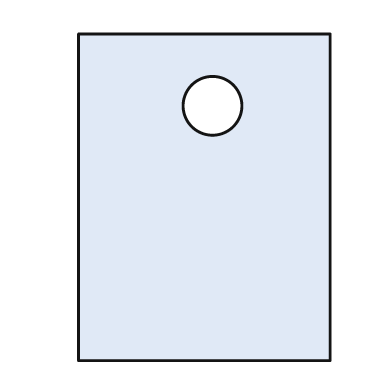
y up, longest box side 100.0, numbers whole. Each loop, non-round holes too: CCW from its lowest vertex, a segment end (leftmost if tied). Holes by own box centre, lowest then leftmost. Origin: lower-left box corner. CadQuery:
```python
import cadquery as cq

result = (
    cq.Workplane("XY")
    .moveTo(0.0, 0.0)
    .lineTo(77.0, 0.0)
    .lineTo(77.0, 100.0)
    .lineTo(0.0, 100.0)
    .close()
    .moveTo(41.0, 78.0)
    .circle(9.0)
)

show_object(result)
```